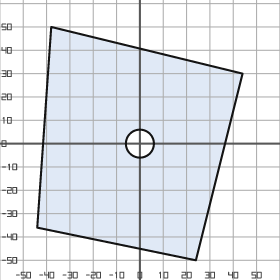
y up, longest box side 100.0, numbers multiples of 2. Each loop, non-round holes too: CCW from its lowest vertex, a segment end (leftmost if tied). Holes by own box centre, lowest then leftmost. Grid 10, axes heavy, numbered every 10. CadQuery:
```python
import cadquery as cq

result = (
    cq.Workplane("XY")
    .moveTo(24.0, -50.0)
    .lineTo(44.0, 30.0)
    .lineTo(-38.0, 50.0)
    .lineTo(-44.0, -36.0)
    .close()
    .moveTo(0.0, 0.0)
    .circle(6.0)
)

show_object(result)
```